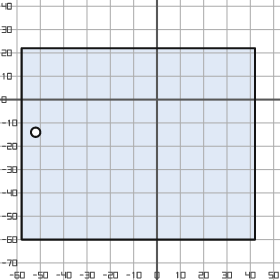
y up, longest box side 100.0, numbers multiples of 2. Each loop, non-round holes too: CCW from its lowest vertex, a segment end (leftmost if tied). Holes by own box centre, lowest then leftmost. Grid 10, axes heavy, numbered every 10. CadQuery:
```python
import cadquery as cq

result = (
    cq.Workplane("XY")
    .moveTo(-58.0, -60.0)
    .lineTo(42.0, -60.0)
    .lineTo(42.0, 22.0)
    .lineTo(-58.0, 22.0)
    .close()
    .moveTo(-52.0, -14.0)
    .circle(2.0)
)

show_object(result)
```